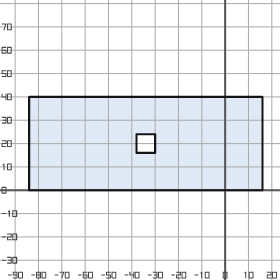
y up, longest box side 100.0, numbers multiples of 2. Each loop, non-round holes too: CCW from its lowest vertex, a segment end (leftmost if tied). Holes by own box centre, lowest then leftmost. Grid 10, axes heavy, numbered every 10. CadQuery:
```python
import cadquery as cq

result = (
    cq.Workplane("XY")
    .moveTo(-84.0, 0.0)
    .lineTo(16.0, 0.0)
    .lineTo(16.0, 40.0)
    .lineTo(-84.0, 40.0)
    .close()
    .moveTo(-38.0, 16.0)
    .lineTo(-30.0, 16.0)
    .lineTo(-30.0, 24.0)
    .lineTo(-38.0, 24.0)
    .close()
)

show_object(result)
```